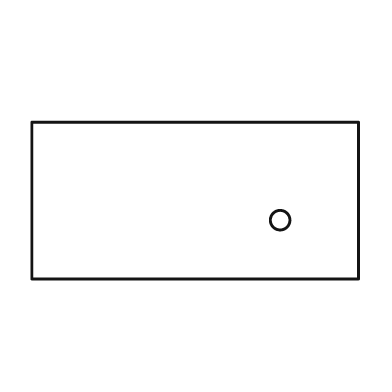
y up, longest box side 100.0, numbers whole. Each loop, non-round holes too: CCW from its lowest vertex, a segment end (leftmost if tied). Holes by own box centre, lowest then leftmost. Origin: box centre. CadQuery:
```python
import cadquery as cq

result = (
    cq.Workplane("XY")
    .moveTo(-50.0, -24.0)
    .lineTo(50.0, -24.0)
    .lineTo(50.0, 24.0)
    .lineTo(-50.0, 24.0)
    .close()
    .moveTo(26.0, -6.0)
    .circle(3.0)
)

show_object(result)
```